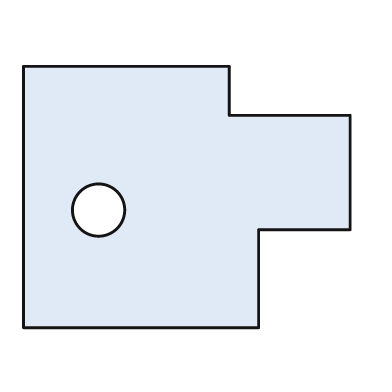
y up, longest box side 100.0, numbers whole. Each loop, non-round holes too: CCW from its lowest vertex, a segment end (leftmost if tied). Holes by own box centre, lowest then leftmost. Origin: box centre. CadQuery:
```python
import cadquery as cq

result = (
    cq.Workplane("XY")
    .moveTo(-50.0, -40.0)
    .lineTo(22.0, -40.0)
    .lineTo(22.0, -10.0)
    .lineTo(50.0, -10.0)
    .lineTo(50.0, 25.0)
    .lineTo(13.0, 25.0)
    .lineTo(13.0, 40.0)
    .lineTo(-50.0, 40.0)
    .close()
    .moveTo(-27.0, -4.0)
    .circle(8.0)
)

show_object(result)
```